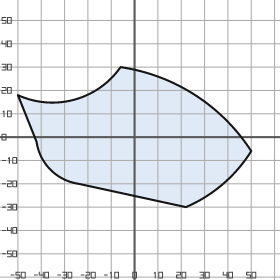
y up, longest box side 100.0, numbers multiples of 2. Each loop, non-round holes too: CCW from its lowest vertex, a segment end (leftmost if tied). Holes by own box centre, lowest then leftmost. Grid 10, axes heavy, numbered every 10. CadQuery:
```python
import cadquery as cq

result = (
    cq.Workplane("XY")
    .moveTo(22.0, -30.0)
    .threePointArc((38.0, -20.0), (50.0, -6.0))
    .threePointArc((26.0, 18.0), (-6.0, 30.0))
    .threePointArc((-26.0, 16.0), (-50.0, 18.0))
    .lineTo(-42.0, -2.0)
    .threePointArc((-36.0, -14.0), (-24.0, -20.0))
    .close()
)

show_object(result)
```